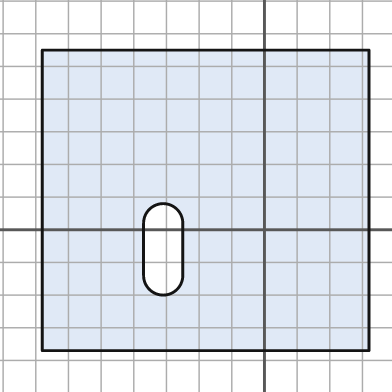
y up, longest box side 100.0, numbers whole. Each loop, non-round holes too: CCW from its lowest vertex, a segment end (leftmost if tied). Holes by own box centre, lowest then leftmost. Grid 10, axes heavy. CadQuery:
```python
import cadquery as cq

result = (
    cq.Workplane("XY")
    .moveTo(-68.0, -37.0)
    .lineTo(32.0, -37.0)
    .lineTo(32.0, 55.0)
    .lineTo(-68.0, 55.0)
    .close()
    .moveTo(-37.0, -14.0)
    .threePointArc((-31.0, -20.0), (-25.0, -14.0))
    .lineTo(-25.0, 2.0)
    .threePointArc((-31.0, 8.0), (-37.0, 2.0))
    .close()
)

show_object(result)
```